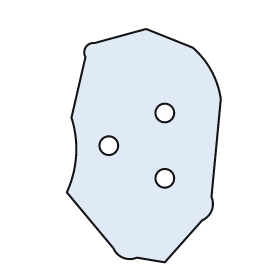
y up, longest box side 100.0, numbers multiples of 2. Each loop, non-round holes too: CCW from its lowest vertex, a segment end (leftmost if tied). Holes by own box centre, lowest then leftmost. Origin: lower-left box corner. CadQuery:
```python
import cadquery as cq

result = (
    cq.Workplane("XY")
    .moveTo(42.0, 0.0)
    .lineTo(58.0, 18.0)
    .threePointArc((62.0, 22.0), (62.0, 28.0))
    .lineTo(66.0, 70.0)
    .threePointArc((62.0, 82.0), (54.0, 92.0))
    .lineTo(34.0, 100.0)
    .lineTo(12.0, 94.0)
    .threePointArc((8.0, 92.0), (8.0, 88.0))
    .lineTo(2.0, 62.0)
    .threePointArc((4.0, 46.0), (0.0, 30.0))
    .lineTo(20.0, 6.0)
    .threePointArc((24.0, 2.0), (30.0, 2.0))
    .close()
    .moveTo(42.0, 36.0)
    .circle(4.0)
    .moveTo(18.0, 50.0)
    .circle(4.0)
    .moveTo(42.0, 64.0)
    .circle(4.0)
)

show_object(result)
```